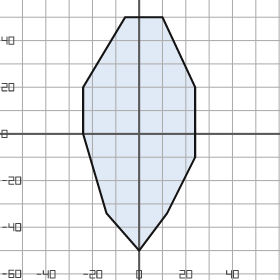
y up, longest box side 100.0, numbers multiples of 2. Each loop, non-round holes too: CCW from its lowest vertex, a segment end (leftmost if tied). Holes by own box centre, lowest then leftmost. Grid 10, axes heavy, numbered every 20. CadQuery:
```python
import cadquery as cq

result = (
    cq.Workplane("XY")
    .moveTo(0.0, -50.0)
    .lineTo(12.0, -34.0)
    .lineTo(24.0, -10.0)
    .lineTo(24.0, 20.0)
    .lineTo(10.0, 50.0)
    .lineTo(-6.0, 50.0)
    .lineTo(-24.0, 20.0)
    .lineTo(-24.0, 0.0)
    .lineTo(-14.0, -34.0)
    .close()
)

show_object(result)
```